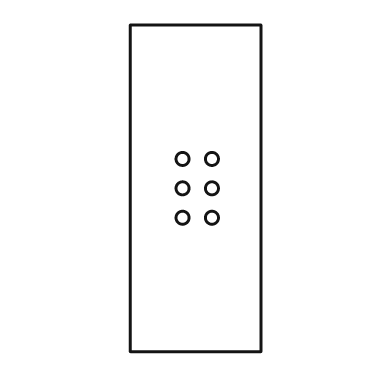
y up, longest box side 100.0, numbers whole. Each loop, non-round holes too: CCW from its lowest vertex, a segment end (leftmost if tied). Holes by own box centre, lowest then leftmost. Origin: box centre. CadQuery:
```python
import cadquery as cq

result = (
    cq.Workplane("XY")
    .moveTo(-20.0, -50.0)
    .lineTo(20.0, -50.0)
    .lineTo(20.0, 50.0)
    .lineTo(-20.0, 50.0)
    .close()
    .moveTo(-4.0, -9.0)
    .circle(2.0)
    .moveTo(5.0, -9.0)
    .circle(2.0)
    .moveTo(-4.0, 0.0)
    .circle(2.0)
    .moveTo(5.0, 0.0)
    .circle(2.0)
    .moveTo(-4.0, 9.0)
    .circle(2.0)
    .moveTo(5.0, 9.0)
    .circle(2.0)
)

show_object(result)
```